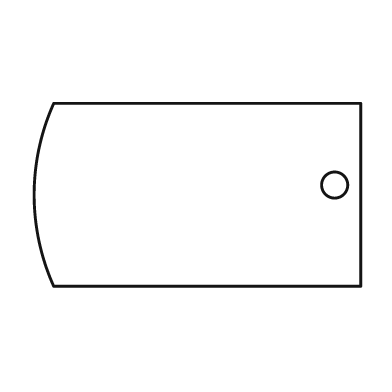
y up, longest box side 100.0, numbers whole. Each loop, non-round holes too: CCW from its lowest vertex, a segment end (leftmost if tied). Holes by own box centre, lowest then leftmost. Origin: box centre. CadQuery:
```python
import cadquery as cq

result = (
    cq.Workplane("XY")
    .moveTo(-44.0, -28.0)
    .lineTo(50.0, -28.0)
    .lineTo(50.0, 28.0)
    .lineTo(-44.0, 28.0)
    .threePointArc((-50.0, 0.0), (-44.0, -28.0))
    .close()
    .moveTo(42.0, 3.0)
    .circle(4.0)
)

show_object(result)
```